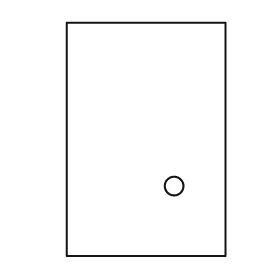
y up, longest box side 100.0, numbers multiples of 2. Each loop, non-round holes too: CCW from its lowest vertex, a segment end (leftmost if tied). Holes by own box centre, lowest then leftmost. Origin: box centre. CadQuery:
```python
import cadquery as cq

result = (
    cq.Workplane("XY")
    .moveTo(-34.0, -50.0)
    .lineTo(34.0, -50.0)
    .lineTo(34.0, 50.0)
    .lineTo(-34.0, 50.0)
    .close()
    .moveTo(12.0, -20.0)
    .circle(4.0)
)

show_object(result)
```